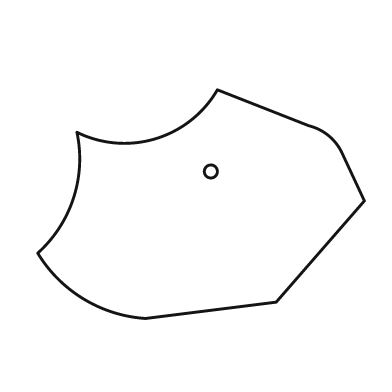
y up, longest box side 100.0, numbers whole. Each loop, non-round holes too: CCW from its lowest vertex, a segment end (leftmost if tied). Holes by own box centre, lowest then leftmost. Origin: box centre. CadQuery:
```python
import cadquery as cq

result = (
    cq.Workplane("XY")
    .moveTo(-17.0, -35.0)
    .lineTo(23.0, -30.0)
    .lineTo(50.0, 1.0)
    .lineTo(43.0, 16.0)
    .threePointArc((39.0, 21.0), (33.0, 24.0))
    .lineTo(5.0, 35.0)
    .threePointArc((-14.0, 20.0), (-38.0, 22.0))
    .threePointArc((-39.0, 2.0), (-50.0, -15.0))
    .threePointArc((-36.0, -29.0), (-17.0, -35.0))
    .close()
    .moveTo(3.0, 10.0)
    .circle(2.0)
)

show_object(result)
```